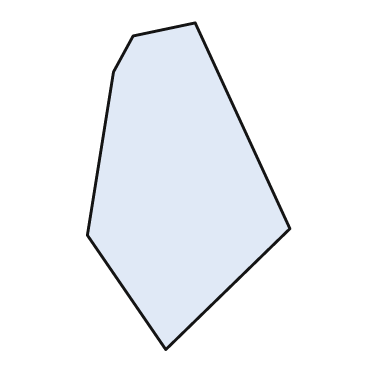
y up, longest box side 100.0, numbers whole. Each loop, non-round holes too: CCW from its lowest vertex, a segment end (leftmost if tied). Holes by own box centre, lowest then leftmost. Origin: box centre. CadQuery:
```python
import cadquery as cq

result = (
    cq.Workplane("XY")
    .moveTo(-7.0, -50.0)
    .lineTo(31.0, -13.0)
    .lineTo(2.0, 50.0)
    .lineTo(-17.0, 46.0)
    .lineTo(-23.0, 35.0)
    .lineTo(-31.0, -15.0)
    .close()
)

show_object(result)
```